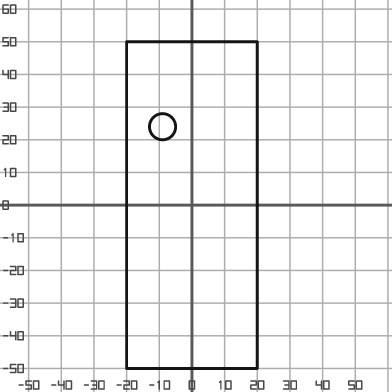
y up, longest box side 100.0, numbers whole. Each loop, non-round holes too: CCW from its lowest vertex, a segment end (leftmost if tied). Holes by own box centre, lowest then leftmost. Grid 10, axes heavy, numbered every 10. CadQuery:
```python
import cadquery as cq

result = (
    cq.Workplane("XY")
    .moveTo(-20.0, -50.0)
    .lineTo(20.0, -50.0)
    .lineTo(20.0, 50.0)
    .lineTo(-20.0, 50.0)
    .close()
    .moveTo(-9.0, 24.0)
    .circle(4.0)
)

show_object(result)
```